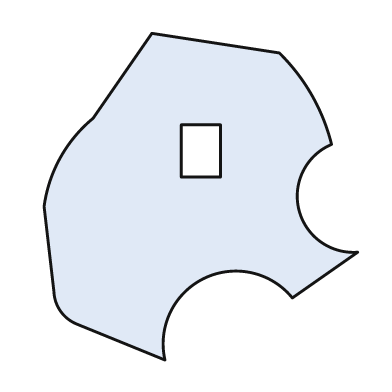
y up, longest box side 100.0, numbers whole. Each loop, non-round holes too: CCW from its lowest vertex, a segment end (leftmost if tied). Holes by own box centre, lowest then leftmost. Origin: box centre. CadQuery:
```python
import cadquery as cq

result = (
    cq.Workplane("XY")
    .moveTo(-11.0, -50.0)
    .threePointArc((1.0, -25.0), (28.0, -31.0))
    .lineTo(48.0, -17.0)
    .threePointArc((30.0, -4.0), (40.0, 16.0))
    .threePointArc((34.0, 31.0), (24.0, 44.0))
    .lineTo(-15.0, 50.0)
    .lineTo(-33.0, 24.0)
    .threePointArc((-43.0, 12.0), (-48.0, -3.0))
    .lineTo(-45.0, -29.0)
    .threePointArc((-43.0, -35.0), (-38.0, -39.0))
    .close()
    .moveTo(-6.0, 6.0)
    .lineTo(6.0, 6.0)
    .lineTo(6.0, 22.0)
    .lineTo(-6.0, 22.0)
    .close()
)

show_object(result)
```